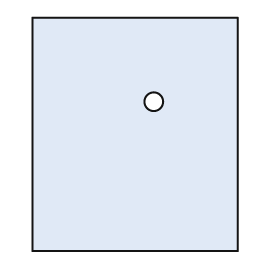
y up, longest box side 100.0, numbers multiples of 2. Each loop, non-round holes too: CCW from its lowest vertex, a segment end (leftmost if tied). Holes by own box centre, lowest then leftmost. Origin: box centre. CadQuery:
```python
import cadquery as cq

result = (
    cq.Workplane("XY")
    .moveTo(-44.0, -50.0)
    .lineTo(44.0, -50.0)
    .lineTo(44.0, 50.0)
    .lineTo(-44.0, 50.0)
    .close()
    .moveTo(8.0, 14.0)
    .circle(4.0)
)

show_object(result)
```